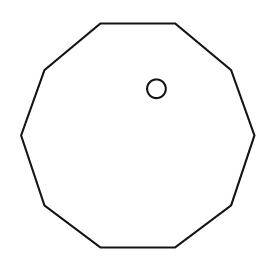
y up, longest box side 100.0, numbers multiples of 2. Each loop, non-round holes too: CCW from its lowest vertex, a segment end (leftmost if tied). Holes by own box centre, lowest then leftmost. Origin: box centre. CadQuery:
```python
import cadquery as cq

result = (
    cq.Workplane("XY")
    .moveTo(-16.0, -48.0)
    .lineTo(16.0, -48.0)
    .lineTo(40.0, -30.0)
    .lineTo(50.0, 0.0)
    .lineTo(40.0, 28.0)
    .lineTo(16.0, 48.0)
    .lineTo(-16.0, 48.0)
    .lineTo(-40.0, 28.0)
    .lineTo(-50.0, 0.0)
    .lineTo(-40.0, -30.0)
    .close()
    .moveTo(8.0, 20.0)
    .circle(4.0)
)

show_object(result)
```